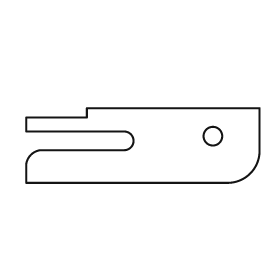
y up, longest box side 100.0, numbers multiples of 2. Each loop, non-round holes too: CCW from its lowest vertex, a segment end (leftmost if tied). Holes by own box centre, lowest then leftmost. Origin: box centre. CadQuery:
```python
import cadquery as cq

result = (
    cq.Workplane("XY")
    .moveTo(-50.0, -16.0)
    .lineTo(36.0, -16.0)
    .threePointArc((46.0, -12.0), (50.0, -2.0))
    .lineTo(50.0, 16.0)
    .lineTo(-24.0, 16.0)
    .lineTo(-24.0, 12.0)
    .lineTo(-50.0, 12.0)
    .lineTo(-50.0, 6.0)
    .lineTo(-8.0, 6.0)
    .threePointArc((-4.0, 2.0), (-8.0, -2.0))
    .lineTo(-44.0, -2.0)
    .threePointArc((-48.0, -4.0), (-50.0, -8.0))
    .close()
    .moveTo(30.0, 4.0)
    .circle(4.0)
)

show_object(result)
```